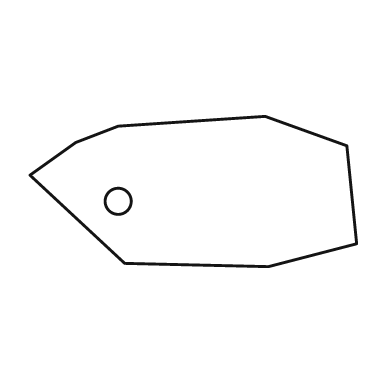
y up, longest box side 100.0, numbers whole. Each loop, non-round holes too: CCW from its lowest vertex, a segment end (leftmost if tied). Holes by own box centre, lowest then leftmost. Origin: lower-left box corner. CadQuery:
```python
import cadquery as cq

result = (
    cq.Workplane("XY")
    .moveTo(73.0, 0.0)
    .lineTo(100.0, 7.0)
    .lineTo(97.0, 37.0)
    .lineTo(72.0, 46.0)
    .lineTo(27.0, 43.0)
    .lineTo(14.0, 38.0)
    .lineTo(0.0, 28.0)
    .lineTo(29.0, 1.0)
    .close()
    .moveTo(27.0, 20.0)
    .circle(4.0)
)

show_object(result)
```